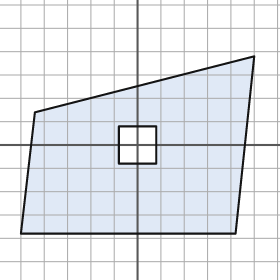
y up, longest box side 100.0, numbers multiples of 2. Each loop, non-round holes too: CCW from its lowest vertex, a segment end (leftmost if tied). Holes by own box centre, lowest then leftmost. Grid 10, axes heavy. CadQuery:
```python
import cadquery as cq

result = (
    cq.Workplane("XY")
    .moveTo(-50.0, -38.0)
    .lineTo(42.0, -38.0)
    .lineTo(50.0, 38.0)
    .lineTo(-44.0, 14.0)
    .close()
    .moveTo(-8.0, -8.0)
    .lineTo(8.0, -8.0)
    .lineTo(8.0, 8.0)
    .lineTo(-8.0, 8.0)
    .close()
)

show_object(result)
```